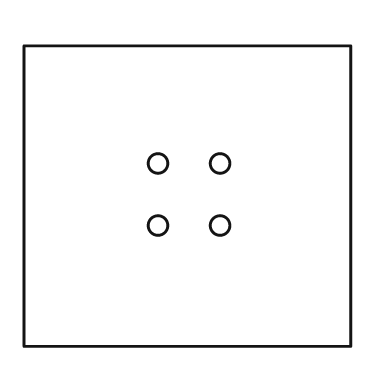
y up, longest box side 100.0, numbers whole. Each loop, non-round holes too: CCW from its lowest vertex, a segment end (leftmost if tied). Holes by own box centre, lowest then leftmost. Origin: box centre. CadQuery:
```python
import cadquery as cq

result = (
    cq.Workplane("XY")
    .moveTo(-50.0, -46.0)
    .lineTo(50.0, -46.0)
    .lineTo(50.0, 46.0)
    .lineTo(-50.0, 46.0)
    .close()
    .moveTo(-9.0, -9.0)
    .circle(3.0)
    .moveTo(10.0, -9.0)
    .circle(3.0)
    .moveTo(-9.0, 10.0)
    .circle(3.0)
    .moveTo(10.0, 10.0)
    .circle(3.0)
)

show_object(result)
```